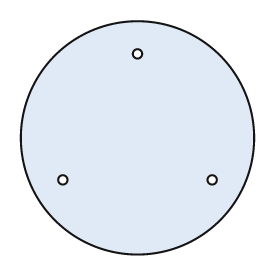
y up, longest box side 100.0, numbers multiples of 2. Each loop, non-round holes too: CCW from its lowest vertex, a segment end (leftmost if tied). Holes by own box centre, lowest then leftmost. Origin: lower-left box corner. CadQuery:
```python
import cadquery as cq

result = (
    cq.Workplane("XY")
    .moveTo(50.0, 50.0)
    .circle(50.0)
    .moveTo(18.0, 32.0)
    .circle(2.0)
    .moveTo(82.0, 32.0)
    .circle(2.0)
    .moveTo(50.0, 86.0)
    .circle(2.0)
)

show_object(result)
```